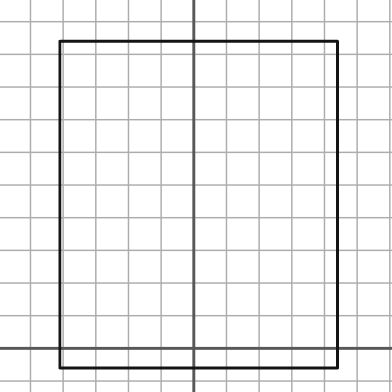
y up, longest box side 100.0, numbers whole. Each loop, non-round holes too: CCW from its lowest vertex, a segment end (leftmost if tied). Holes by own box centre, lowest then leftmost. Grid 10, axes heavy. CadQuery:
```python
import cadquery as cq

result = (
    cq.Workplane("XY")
    .moveTo(-41.0, -6.0)
    .lineTo(44.0, -6.0)
    .lineTo(44.0, 94.0)
    .lineTo(-41.0, 94.0)
    .close()
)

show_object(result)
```